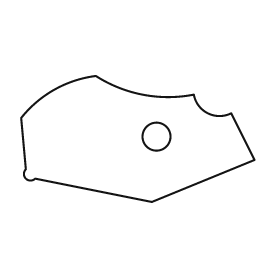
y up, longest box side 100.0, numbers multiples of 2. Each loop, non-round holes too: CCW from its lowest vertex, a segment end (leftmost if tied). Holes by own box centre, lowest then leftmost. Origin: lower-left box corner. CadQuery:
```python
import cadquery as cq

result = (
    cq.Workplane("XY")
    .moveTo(56.0, 0.0)
    .lineTo(100.0, 18.0)
    .lineTo(90.0, 38.0)
    .threePointArc((80.0, 38.0), (74.0, 46.0))
    .threePointArc((52.0, 46.0), (32.0, 54.0))
    .threePointArc((14.0, 48.0), (0.0, 36.0))
    .lineTo(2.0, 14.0)
    .threePointArc((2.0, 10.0), (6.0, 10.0))
    .close()
    .moveTo(58.0, 28.0)
    .circle(6.0)
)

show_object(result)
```